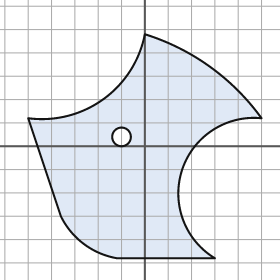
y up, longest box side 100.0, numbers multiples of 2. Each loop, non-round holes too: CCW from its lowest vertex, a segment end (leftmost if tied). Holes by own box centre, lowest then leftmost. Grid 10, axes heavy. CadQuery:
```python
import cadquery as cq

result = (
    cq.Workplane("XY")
    .moveTo(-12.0, -48.0)
    .lineTo(30.0, -48.0)
    .threePointArc((16.0, -10.0), (50.0, 12.0))
    .threePointArc((28.0, 34.0), (0.0, 48.0))
    .threePointArc((-18.0, 20.0), (-50.0, 12.0))
    .lineTo(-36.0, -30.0)
    .threePointArc((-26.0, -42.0), (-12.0, -48.0))
    .close()
    .moveTo(-10.0, 4.0)
    .circle(4.0)
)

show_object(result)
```